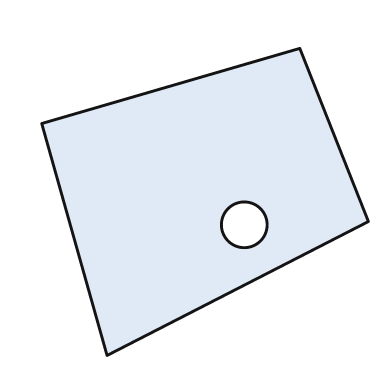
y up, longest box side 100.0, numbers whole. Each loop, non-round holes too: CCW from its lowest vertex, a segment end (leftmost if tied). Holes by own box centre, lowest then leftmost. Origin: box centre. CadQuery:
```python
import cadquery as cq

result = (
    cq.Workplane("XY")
    .moveTo(-30.0, -47.0)
    .lineTo(50.0, -6.0)
    .lineTo(29.0, 47.0)
    .lineTo(-50.0, 24.0)
    .close()
    .moveTo(12.0, -7.0)
    .circle(7.0)
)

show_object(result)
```